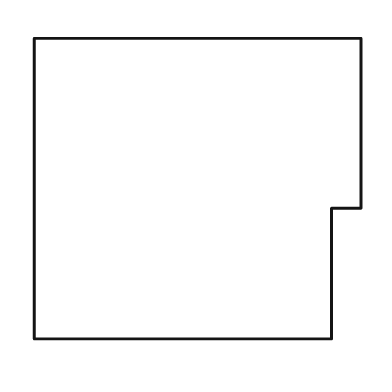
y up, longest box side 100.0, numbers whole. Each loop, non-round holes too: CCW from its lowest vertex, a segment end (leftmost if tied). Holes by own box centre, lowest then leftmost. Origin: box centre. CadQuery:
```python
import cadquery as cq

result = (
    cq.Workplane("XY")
    .moveTo(-50.0, -46.0)
    .lineTo(41.0, -46.0)
    .lineTo(41.0, -6.0)
    .lineTo(50.0, -6.0)
    .lineTo(50.0, 46.0)
    .lineTo(-50.0, 46.0)
    .close()
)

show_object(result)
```